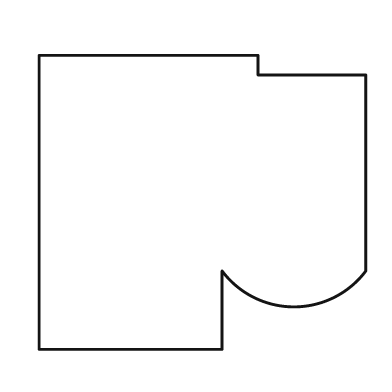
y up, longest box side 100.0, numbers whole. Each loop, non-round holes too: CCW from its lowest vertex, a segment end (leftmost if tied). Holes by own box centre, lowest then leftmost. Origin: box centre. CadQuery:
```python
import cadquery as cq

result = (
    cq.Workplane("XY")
    .moveTo(-50.0, -45.0)
    .lineTo(6.0, -45.0)
    .lineTo(6.0, -21.0)
    .threePointArc((28.0, -32.0), (50.0, -21.0))
    .lineTo(50.0, 39.0)
    .lineTo(17.0, 39.0)
    .lineTo(17.0, 45.0)
    .lineTo(-50.0, 45.0)
    .close()
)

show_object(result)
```